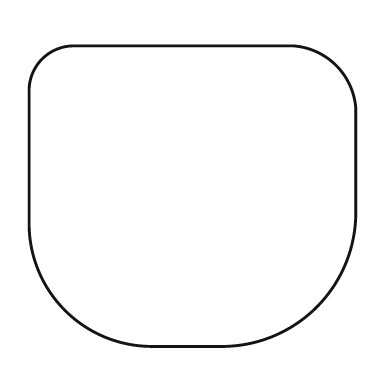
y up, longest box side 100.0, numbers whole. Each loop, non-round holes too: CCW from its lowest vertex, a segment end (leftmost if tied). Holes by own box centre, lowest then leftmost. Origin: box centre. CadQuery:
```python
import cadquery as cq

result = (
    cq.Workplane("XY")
    .moveTo(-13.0, -46.0)
    .lineTo(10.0, -46.0)
    .threePointArc((38.0, -34.0), (50.0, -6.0))
    .lineTo(50.0, 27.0)
    .threePointArc((44.0, 40.0), (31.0, 46.0))
    .lineTo(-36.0, 46.0)
    .threePointArc((-46.0, 42.0), (-50.0, 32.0))
    .lineTo(-50.0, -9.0)
    .threePointArc((-39.0, -35.0), (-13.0, -46.0))
    .close()
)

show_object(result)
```